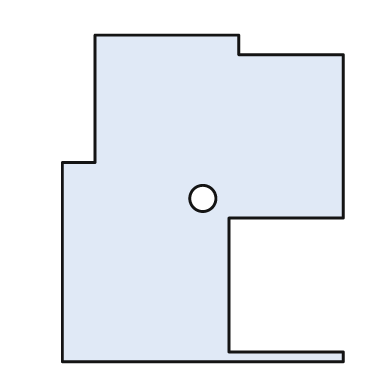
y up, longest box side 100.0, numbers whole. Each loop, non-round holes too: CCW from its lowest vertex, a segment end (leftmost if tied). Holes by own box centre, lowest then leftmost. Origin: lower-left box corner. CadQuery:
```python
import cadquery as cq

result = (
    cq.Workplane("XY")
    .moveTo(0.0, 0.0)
    .lineTo(86.0, 0.0)
    .lineTo(86.0, 3.0)
    .lineTo(51.0, 3.0)
    .lineTo(51.0, 44.0)
    .lineTo(86.0, 44.0)
    .lineTo(86.0, 94.0)
    .lineTo(54.0, 94.0)
    .lineTo(54.0, 100.0)
    .lineTo(10.0, 100.0)
    .lineTo(10.0, 61.0)
    .lineTo(0.0, 61.0)
    .close()
    .moveTo(43.0, 50.0)
    .circle(4.0)
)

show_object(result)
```